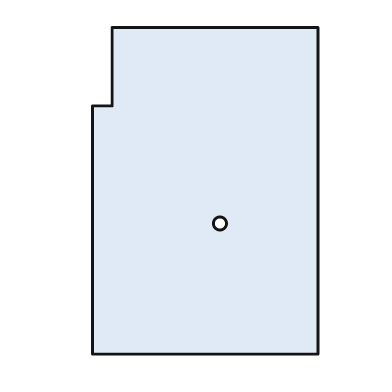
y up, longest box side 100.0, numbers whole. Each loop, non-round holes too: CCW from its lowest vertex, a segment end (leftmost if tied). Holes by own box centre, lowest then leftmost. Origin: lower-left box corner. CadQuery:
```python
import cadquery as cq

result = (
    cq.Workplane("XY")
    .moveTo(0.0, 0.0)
    .lineTo(69.0, 0.0)
    .lineTo(69.0, 100.0)
    .lineTo(6.0, 100.0)
    .lineTo(6.0, 76.0)
    .lineTo(0.0, 76.0)
    .close()
    .moveTo(39.0, 40.0)
    .circle(2.0)
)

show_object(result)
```